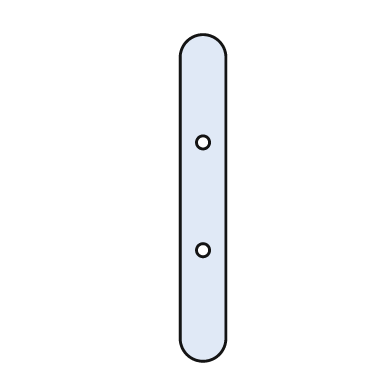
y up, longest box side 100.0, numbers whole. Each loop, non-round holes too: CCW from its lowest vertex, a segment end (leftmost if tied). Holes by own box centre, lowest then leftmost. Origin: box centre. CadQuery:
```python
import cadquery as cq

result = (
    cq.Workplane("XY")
    .moveTo(-7.0, -43.0)
    .threePointArc((0.0, -50.0), (7.0, -43.0))
    .lineTo(7.0, 43.0)
    .threePointArc((0.0, 50.0), (-7.0, 43.0))
    .close()
    .moveTo(0.0, -16.0)
    .circle(2.0)
    .moveTo(0.0, 17.0)
    .circle(2.0)
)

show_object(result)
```